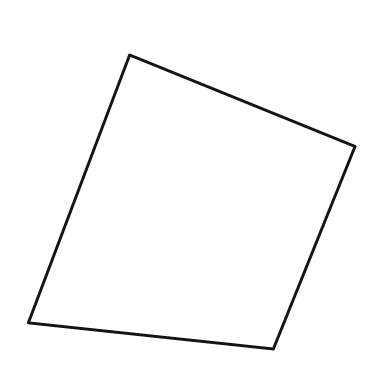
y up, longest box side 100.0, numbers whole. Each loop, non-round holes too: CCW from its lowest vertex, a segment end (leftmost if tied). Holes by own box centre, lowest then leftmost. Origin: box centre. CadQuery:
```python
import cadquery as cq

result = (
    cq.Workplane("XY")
    .moveTo(25.0, -45.0)
    .lineTo(50.0, 17.0)
    .lineTo(-19.0, 45.0)
    .lineTo(-50.0, -37.0)
    .close()
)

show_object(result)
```